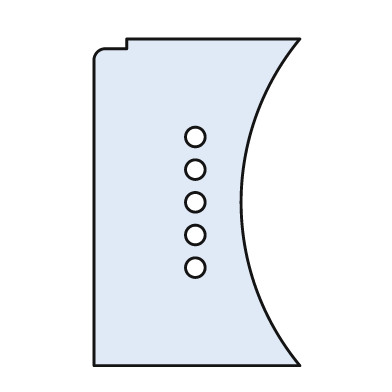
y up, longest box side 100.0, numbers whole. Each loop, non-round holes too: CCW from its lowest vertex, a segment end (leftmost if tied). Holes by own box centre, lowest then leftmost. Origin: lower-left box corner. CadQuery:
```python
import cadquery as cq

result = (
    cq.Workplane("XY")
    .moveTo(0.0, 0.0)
    .lineTo(63.0, 0.0)
    .threePointArc((45.0, 50.0), (63.0, 100.0))
    .lineTo(10.0, 100.0)
    .lineTo(10.0, 97.0)
    .lineTo(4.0, 97.0)
    .threePointArc((1.0, 96.0), (0.0, 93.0))
    .close()
    .moveTo(31.0, 30.0)
    .circle(3.0)
    .moveTo(31.0, 40.0)
    .circle(3.0)
    .moveTo(31.0, 50.0)
    .circle(3.0)
    .moveTo(31.0, 60.0)
    .circle(3.0)
    .moveTo(31.0, 70.0)
    .circle(3.0)
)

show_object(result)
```